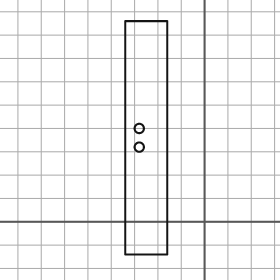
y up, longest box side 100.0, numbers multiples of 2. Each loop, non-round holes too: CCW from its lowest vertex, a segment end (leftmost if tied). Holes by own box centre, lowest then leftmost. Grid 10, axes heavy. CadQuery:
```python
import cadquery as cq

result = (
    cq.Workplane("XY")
    .moveTo(-34.0, -14.0)
    .lineTo(-16.0, -14.0)
    .lineTo(-16.0, 86.0)
    .lineTo(-34.0, 86.0)
    .close()
    .moveTo(-28.0, 32.0)
    .circle(2.0)
    .moveTo(-28.0, 40.0)
    .circle(2.0)
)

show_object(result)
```